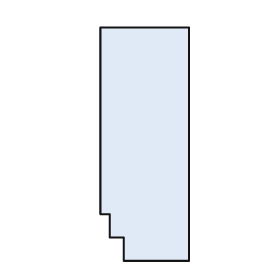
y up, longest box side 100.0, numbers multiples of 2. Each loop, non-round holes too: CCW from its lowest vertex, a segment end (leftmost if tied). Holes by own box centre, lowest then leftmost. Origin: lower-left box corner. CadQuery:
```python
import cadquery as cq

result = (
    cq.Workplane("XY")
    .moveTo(10.0, 0.0)
    .lineTo(38.0, 0.0)
    .lineTo(38.0, 100.0)
    .lineTo(0.0, 100.0)
    .lineTo(0.0, 20.0)
    .lineTo(4.0, 20.0)
    .lineTo(4.0, 10.0)
    .lineTo(10.0, 10.0)
    .close()
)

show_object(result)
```